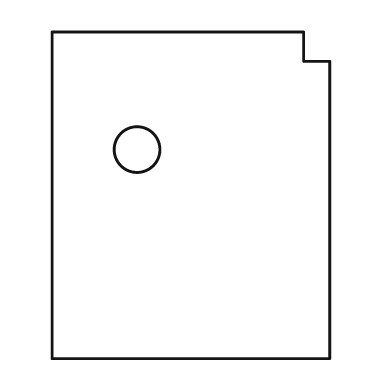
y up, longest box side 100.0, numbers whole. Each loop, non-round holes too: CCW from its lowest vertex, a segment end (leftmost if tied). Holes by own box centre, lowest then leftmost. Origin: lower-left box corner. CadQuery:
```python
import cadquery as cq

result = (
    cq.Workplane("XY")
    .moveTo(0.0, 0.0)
    .lineTo(85.0, 0.0)
    .lineTo(85.0, 91.0)
    .lineTo(77.0, 91.0)
    .lineTo(77.0, 100.0)
    .lineTo(0.0, 100.0)
    .close()
    .moveTo(26.0, 64.0)
    .circle(7.0)
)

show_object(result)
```